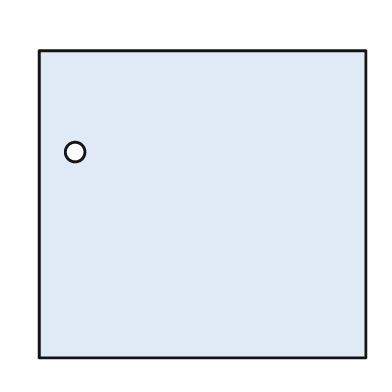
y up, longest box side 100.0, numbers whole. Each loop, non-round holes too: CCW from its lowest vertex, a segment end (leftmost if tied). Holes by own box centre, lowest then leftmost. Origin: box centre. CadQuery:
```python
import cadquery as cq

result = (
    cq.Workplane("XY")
    .moveTo(-50.0, -47.0)
    .lineTo(50.0, -47.0)
    .lineTo(50.0, 47.0)
    .lineTo(-50.0, 47.0)
    .close()
    .moveTo(-39.0, 16.0)
    .circle(3.0)
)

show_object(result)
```